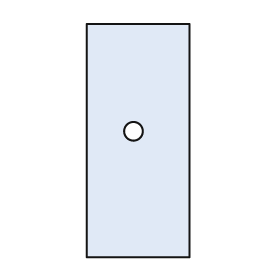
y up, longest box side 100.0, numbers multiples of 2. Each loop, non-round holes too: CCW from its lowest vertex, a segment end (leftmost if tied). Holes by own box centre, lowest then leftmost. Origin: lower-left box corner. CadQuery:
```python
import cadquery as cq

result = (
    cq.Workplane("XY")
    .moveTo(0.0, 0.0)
    .lineTo(44.0, 0.0)
    .lineTo(44.0, 100.0)
    .lineTo(0.0, 100.0)
    .close()
    .moveTo(20.0, 54.0)
    .circle(4.0)
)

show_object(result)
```